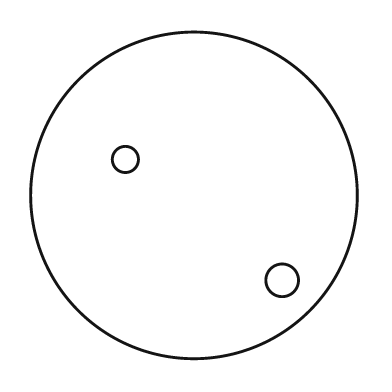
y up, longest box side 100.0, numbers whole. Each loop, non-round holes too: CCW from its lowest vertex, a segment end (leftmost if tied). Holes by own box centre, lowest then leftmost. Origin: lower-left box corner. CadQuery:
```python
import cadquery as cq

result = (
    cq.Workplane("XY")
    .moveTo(50.0, 50.0)
    .circle(50.0)
    .moveTo(77.0, 24.0)
    .circle(5.0)
    .moveTo(29.0, 61.0)
    .circle(4.0)
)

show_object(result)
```